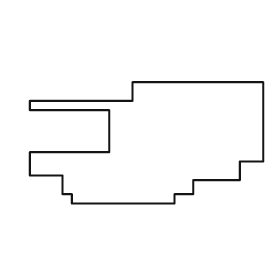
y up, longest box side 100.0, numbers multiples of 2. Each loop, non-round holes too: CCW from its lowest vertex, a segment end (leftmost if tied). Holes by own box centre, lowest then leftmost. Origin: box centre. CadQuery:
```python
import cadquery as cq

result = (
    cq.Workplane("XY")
    .moveTo(-32.0, -26.0)
    .lineTo(12.0, -26.0)
    .lineTo(12.0, -22.0)
    .lineTo(20.0, -22.0)
    .lineTo(20.0, -16.0)
    .lineTo(40.0, -16.0)
    .lineTo(40.0, -8.0)
    .lineTo(50.0, -8.0)
    .lineTo(50.0, 26.0)
    .lineTo(-6.0, 26.0)
    .lineTo(-6.0, 18.0)
    .lineTo(-50.0, 18.0)
    .lineTo(-50.0, 14.0)
    .lineTo(-16.0, 14.0)
    .lineTo(-16.0, -4.0)
    .lineTo(-50.0, -4.0)
    .lineTo(-50.0, -14.0)
    .lineTo(-36.0, -14.0)
    .lineTo(-36.0, -22.0)
    .lineTo(-32.0, -22.0)
    .close()
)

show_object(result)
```